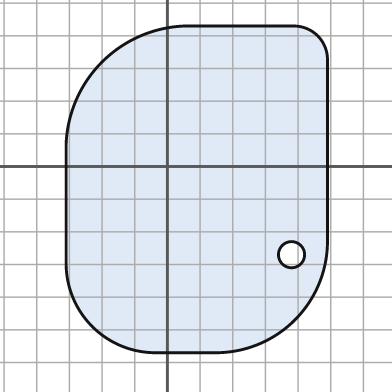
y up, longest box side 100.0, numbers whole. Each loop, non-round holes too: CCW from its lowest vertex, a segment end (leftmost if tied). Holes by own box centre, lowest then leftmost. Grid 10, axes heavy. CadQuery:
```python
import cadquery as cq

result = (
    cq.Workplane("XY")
    .moveTo(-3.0, -57.0)
    .lineTo(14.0, -57.0)
    .threePointArc((39.0, -47.0), (49.0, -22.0))
    .lineTo(49.0, 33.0)
    .threePointArc((46.0, 40.0), (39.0, 43.0))
    .lineTo(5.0, 43.0)
    .threePointArc((-20.0, 32.0), (-31.0, 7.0))
    .lineTo(-31.0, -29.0)
    .threePointArc((-23.0, -49.0), (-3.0, -57.0))
    .close()
    .moveTo(38.0, -27.0)
    .circle(4.0)
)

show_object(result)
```